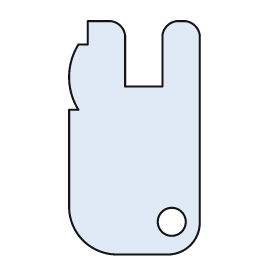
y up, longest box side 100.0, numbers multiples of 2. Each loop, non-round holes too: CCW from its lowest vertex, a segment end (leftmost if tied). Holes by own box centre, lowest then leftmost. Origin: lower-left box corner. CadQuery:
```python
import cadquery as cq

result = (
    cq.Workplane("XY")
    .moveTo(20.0, 0.0)
    .lineTo(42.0, 0.0)
    .threePointArc((52.0, 4.0), (56.0, 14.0))
    .lineTo(56.0, 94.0)
    .threePointArc((54.0, 98.0), (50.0, 100.0))
    .lineTo(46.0, 100.0)
    .threePointArc((42.0, 98.0), (40.0, 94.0))
    .lineTo(40.0, 72.0)
    .lineTo(24.0, 72.0)
    .lineTo(24.0, 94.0)
    .threePointArc((22.0, 98.0), (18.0, 100.0))
    .lineTo(8.0, 100.0)
    .lineTo(8.0, 90.0)
    .lineTo(4.0, 90.0)
    .threePointArc((0.0, 76.0), (4.0, 62.0))
    .lineTo(0.0, 62.0)
    .lineTo(0.0, 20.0)
    .threePointArc((6.0, 6.0), (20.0, 0.0))
    .close()
    .moveTo(44.0, 14.0)
    .circle(6.0)
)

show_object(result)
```